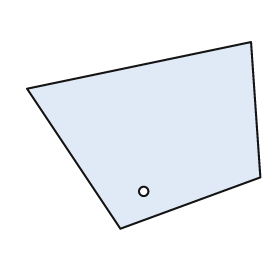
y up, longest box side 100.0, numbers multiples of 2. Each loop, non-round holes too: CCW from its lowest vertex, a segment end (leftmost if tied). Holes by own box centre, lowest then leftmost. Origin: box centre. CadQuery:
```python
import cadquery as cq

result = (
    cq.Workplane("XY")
    .moveTo(-10.0, -40.0)
    .lineTo(50.0, -18.0)
    .lineTo(46.0, 40.0)
    .lineTo(-50.0, 20.0)
    .close()
    .moveTo(0.0, -24.0)
    .circle(2.0)
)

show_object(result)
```